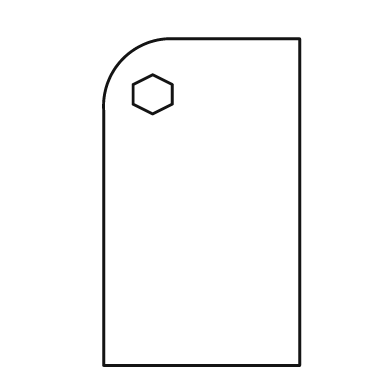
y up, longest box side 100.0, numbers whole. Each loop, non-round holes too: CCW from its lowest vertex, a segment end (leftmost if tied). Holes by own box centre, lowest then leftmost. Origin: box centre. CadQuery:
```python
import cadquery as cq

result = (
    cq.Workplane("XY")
    .moveTo(-30.0, -50.0)
    .lineTo(30.0, -50.0)
    .lineTo(30.0, 50.0)
    .lineTo(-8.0, 50.0)
    .threePointArc((-24.0, 44.0), (-30.0, 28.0))
    .close()
    .moveTo(-15.0, 27.0)
    .lineTo(-9.0, 30.0)
    .lineTo(-9.0, 36.0)
    .lineTo(-15.0, 39.0)
    .lineTo(-21.0, 36.0)
    .lineTo(-21.0, 30.0)
    .close()
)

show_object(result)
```